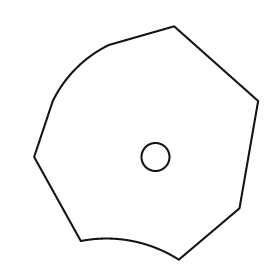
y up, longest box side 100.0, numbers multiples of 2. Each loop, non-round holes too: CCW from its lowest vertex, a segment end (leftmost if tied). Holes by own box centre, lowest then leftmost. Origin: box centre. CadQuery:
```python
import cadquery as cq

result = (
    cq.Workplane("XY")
    .moveTo(14.0, -50.0)
    .lineTo(40.0, -28.0)
    .lineTo(48.0, 18.0)
    .lineTo(12.0, 50.0)
    .lineTo(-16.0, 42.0)
    .threePointArc((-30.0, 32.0), (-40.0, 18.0))
    .lineTo(-48.0, -6.0)
    .lineTo(-28.0, -42.0)
    .threePointArc((-6.0, -42.0), (14.0, -50.0))
    .close()
    .moveTo(4.0, -6.0)
    .circle(6.0)
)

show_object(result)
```